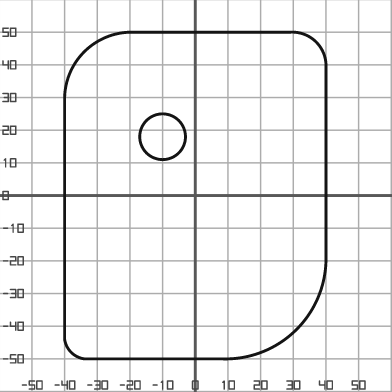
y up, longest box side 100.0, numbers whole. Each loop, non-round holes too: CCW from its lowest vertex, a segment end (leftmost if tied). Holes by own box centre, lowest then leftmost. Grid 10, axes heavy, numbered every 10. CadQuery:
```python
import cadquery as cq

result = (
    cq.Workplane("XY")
    .moveTo(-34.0, -50.0)
    .lineTo(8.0, -50.0)
    .threePointArc((31.0, -41.0), (40.0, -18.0))
    .lineTo(40.0, 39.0)
    .threePointArc((37.0, 47.0), (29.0, 50.0))
    .lineTo(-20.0, 50.0)
    .threePointArc((-34.0, 44.0), (-40.0, 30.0))
    .lineTo(-40.0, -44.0)
    .threePointArc((-38.0, -48.0), (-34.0, -50.0))
    .close()
    .moveTo(-10.0, 18.0)
    .circle(7.0)
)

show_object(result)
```